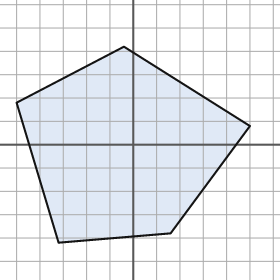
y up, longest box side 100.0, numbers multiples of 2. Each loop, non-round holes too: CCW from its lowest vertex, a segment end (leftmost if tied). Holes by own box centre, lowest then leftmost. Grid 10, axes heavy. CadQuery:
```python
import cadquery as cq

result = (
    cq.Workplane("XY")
    .moveTo(-32.0, -42.0)
    .lineTo(16.0, -38.0)
    .lineTo(50.0, 8.0)
    .lineTo(-4.0, 42.0)
    .lineTo(-50.0, 18.0)
    .close()
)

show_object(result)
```